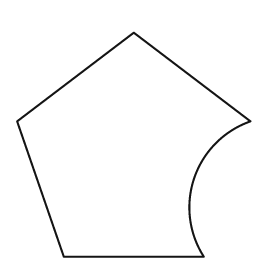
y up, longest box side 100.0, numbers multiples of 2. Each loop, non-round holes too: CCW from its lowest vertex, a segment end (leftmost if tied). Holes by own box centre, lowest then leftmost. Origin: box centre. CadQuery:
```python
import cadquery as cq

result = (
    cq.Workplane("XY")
    .moveTo(-30.0, -48.0)
    .lineTo(30.0, -48.0)
    .threePointArc((26.0, -14.0), (50.0, 10.0))
    .lineTo(0.0, 48.0)
    .lineTo(-50.0, 10.0)
    .close()
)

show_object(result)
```